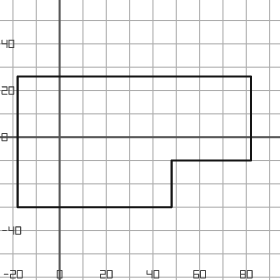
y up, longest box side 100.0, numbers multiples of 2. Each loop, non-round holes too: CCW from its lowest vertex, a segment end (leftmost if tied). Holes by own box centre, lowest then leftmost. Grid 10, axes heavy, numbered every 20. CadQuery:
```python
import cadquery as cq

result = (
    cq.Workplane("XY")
    .moveTo(-18.0, -30.0)
    .lineTo(48.0, -30.0)
    .lineTo(48.0, -10.0)
    .lineTo(82.0, -10.0)
    .lineTo(82.0, 26.0)
    .lineTo(-18.0, 26.0)
    .close()
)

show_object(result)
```